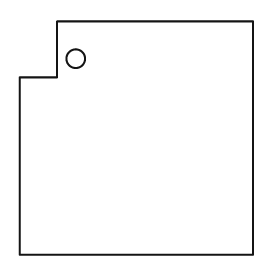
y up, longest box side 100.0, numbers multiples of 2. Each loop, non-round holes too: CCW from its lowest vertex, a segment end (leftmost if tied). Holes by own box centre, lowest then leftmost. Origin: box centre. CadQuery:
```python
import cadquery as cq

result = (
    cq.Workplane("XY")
    .moveTo(-50.0, -50.0)
    .lineTo(50.0, -50.0)
    .lineTo(50.0, 50.0)
    .lineTo(-34.0, 50.0)
    .lineTo(-34.0, 26.0)
    .lineTo(-50.0, 26.0)
    .close()
    .moveTo(-26.0, 34.0)
    .circle(4.0)
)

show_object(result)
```